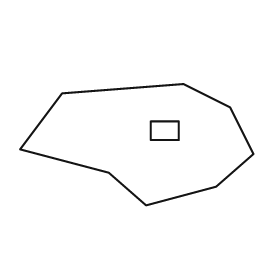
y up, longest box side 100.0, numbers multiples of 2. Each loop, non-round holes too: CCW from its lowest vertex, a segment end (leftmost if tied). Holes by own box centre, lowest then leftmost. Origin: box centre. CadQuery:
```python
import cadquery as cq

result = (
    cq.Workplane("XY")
    .moveTo(4.0, -26.0)
    .lineTo(34.0, -18.0)
    .lineTo(50.0, -4.0)
    .lineTo(40.0, 16.0)
    .lineTo(20.0, 26.0)
    .lineTo(-32.0, 22.0)
    .lineTo(-50.0, -2.0)
    .lineTo(-12.0, -12.0)
    .close()
    .moveTo(6.0, 2.0)
    .lineTo(18.0, 2.0)
    .lineTo(18.0, 10.0)
    .lineTo(6.0, 10.0)
    .close()
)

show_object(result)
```